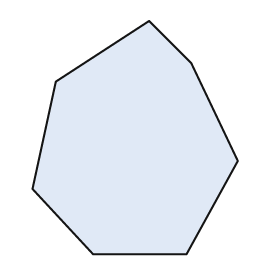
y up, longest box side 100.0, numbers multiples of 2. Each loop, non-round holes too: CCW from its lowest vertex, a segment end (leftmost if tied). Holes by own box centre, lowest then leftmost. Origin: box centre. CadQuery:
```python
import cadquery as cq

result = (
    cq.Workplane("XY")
    .moveTo(-18.0, -50.0)
    .lineTo(22.0, -50.0)
    .lineTo(44.0, -10.0)
    .lineTo(24.0, 32.0)
    .lineTo(6.0, 50.0)
    .lineTo(-34.0, 24.0)
    .lineTo(-44.0, -22.0)
    .close()
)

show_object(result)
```